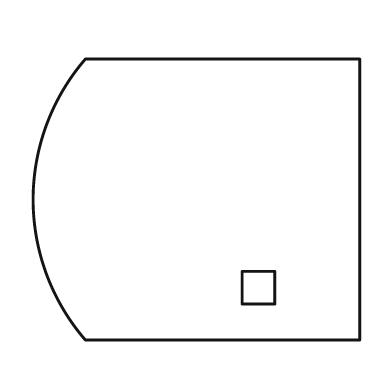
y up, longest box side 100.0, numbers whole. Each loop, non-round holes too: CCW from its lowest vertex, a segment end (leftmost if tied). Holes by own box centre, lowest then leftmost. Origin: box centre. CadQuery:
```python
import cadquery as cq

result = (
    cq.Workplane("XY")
    .moveTo(-34.0, -43.0)
    .lineTo(50.0, -43.0)
    .lineTo(50.0, 43.0)
    .lineTo(-34.0, 43.0)
    .threePointArc((-50.0, 0.0), (-34.0, -43.0))
    .close()
    .moveTo(14.0, -32.0)
    .lineTo(24.0, -32.0)
    .lineTo(24.0, -22.0)
    .lineTo(14.0, -22.0)
    .close()
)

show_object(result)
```